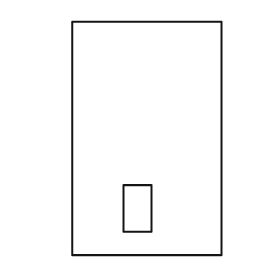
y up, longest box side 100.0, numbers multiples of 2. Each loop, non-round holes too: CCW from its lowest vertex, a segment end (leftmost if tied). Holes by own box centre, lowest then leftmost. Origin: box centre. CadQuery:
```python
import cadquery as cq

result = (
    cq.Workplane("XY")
    .moveTo(-32.0, -50.0)
    .lineTo(32.0, -50.0)
    .lineTo(32.0, 50.0)
    .lineTo(-32.0, 50.0)
    .close()
    .moveTo(-10.0, -40.0)
    .lineTo(2.0, -40.0)
    .lineTo(2.0, -20.0)
    .lineTo(-10.0, -20.0)
    .close()
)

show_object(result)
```